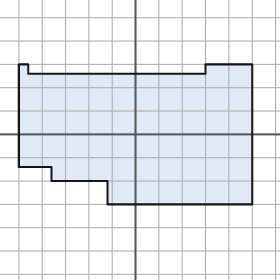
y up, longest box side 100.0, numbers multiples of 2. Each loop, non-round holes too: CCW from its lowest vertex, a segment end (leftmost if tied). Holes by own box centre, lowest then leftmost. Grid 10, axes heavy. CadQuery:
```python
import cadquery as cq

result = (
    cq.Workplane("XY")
    .moveTo(-12.0, -30.0)
    .lineTo(50.0, -30.0)
    .lineTo(50.0, 30.0)
    .lineTo(30.0, 30.0)
    .lineTo(30.0, 26.0)
    .lineTo(-46.0, 26.0)
    .lineTo(-46.0, 30.0)
    .lineTo(-50.0, 30.0)
    .lineTo(-50.0, -14.0)
    .lineTo(-36.0, -14.0)
    .lineTo(-36.0, -20.0)
    .lineTo(-12.0, -20.0)
    .close()
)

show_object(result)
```